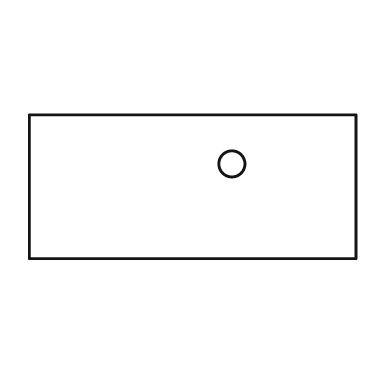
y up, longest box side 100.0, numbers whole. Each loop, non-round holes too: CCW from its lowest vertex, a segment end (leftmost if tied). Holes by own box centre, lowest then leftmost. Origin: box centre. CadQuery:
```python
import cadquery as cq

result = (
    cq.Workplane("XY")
    .moveTo(-50.0, -22.0)
    .lineTo(50.0, -22.0)
    .lineTo(50.0, 22.0)
    .lineTo(-50.0, 22.0)
    .close()
    .moveTo(12.0, 7.0)
    .circle(4.0)
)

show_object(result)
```